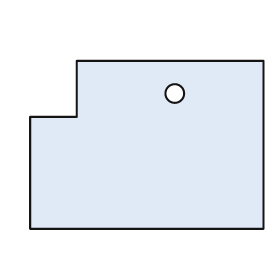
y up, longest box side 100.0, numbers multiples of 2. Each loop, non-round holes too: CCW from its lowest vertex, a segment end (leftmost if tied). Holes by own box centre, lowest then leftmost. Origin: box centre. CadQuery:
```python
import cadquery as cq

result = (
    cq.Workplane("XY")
    .moveTo(-50.0, -36.0)
    .lineTo(50.0, -36.0)
    .lineTo(50.0, 36.0)
    .lineTo(-30.0, 36.0)
    .lineTo(-30.0, 12.0)
    .lineTo(-50.0, 12.0)
    .close()
    .moveTo(12.0, 22.0)
    .circle(4.0)
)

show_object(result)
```